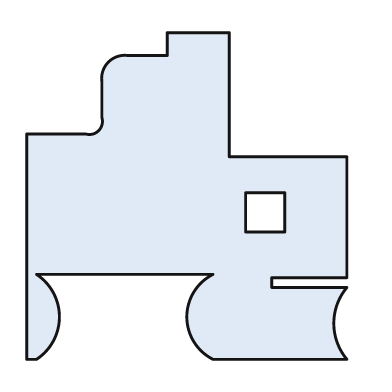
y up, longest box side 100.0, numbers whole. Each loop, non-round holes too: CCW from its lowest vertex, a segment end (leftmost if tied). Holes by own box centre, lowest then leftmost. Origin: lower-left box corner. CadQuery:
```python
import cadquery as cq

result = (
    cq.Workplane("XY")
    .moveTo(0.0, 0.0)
    .lineTo(3.0, 0.0)
    .threePointArc((10.0, 13.0), (3.0, 26.0))
    .lineTo(57.0, 26.0)
    .threePointArc((49.0, 13.0), (57.0, 0.0))
    .lineTo(98.0, 0.0)
    .threePointArc((94.0, 11.0), (98.0, 22.0))
    .lineTo(75.0, 22.0)
    .lineTo(75.0, 25.0)
    .lineTo(98.0, 25.0)
    .lineTo(98.0, 62.0)
    .lineTo(62.0, 62.0)
    .lineTo(62.0, 100.0)
    .lineTo(43.0, 100.0)
    .lineTo(43.0, 93.0)
    .lineTo(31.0, 93.0)
    .threePointArc((25.0, 91.0), (23.0, 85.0))
    .lineTo(23.0, 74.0)
    .threePointArc((22.0, 70.0), (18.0, 69.0))
    .lineTo(0.0, 69.0)
    .close()
    .moveTo(67.0, 39.0)
    .lineTo(79.0, 39.0)
    .lineTo(79.0, 51.0)
    .lineTo(67.0, 51.0)
    .close()
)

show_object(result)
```